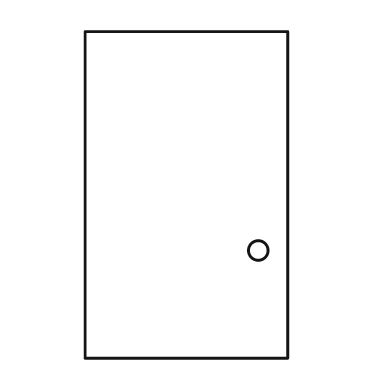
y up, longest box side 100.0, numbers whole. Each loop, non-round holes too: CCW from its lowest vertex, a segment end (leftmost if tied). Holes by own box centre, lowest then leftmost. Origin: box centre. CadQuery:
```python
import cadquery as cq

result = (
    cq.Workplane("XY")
    .moveTo(-31.0, -50.0)
    .lineTo(31.0, -50.0)
    .lineTo(31.0, 50.0)
    .lineTo(-31.0, 50.0)
    .close()
    .moveTo(22.0, -17.0)
    .circle(3.0)
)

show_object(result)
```